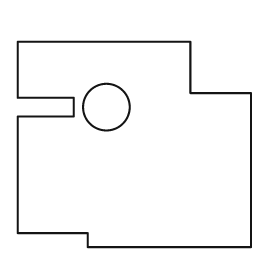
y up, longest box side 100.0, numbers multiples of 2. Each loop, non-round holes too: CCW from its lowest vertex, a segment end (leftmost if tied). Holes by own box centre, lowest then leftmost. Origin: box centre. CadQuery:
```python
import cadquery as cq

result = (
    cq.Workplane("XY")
    .moveTo(-20.0, -44.0)
    .lineTo(50.0, -44.0)
    .lineTo(50.0, 22.0)
    .lineTo(24.0, 22.0)
    .lineTo(24.0, 44.0)
    .lineTo(-50.0, 44.0)
    .lineTo(-50.0, 20.0)
    .lineTo(-26.0, 20.0)
    .lineTo(-26.0, 12.0)
    .lineTo(-50.0, 12.0)
    .lineTo(-50.0, -38.0)
    .lineTo(-20.0, -38.0)
    .close()
    .moveTo(-12.0, 16.0)
    .circle(10.0)
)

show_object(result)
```